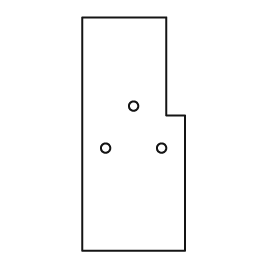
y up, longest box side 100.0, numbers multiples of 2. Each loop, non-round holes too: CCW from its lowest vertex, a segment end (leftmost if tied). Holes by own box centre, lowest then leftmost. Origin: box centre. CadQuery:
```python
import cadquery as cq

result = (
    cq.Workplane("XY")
    .moveTo(-22.0, -50.0)
    .lineTo(22.0, -50.0)
    .lineTo(22.0, 8.0)
    .lineTo(14.0, 8.0)
    .lineTo(14.0, 50.0)
    .lineTo(-22.0, 50.0)
    .close()
    .moveTo(-12.0, -6.0)
    .circle(2.0)
    .moveTo(12.0, -6.0)
    .circle(2.0)
    .moveTo(0.0, 12.0)
    .circle(2.0)
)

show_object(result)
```